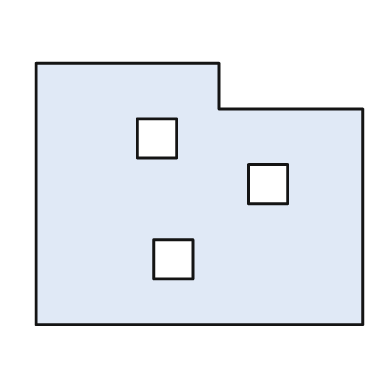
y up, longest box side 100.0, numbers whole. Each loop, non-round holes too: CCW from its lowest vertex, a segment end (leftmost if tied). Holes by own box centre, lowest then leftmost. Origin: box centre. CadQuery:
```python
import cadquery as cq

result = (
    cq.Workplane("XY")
    .moveTo(-50.0, -40.0)
    .lineTo(50.0, -40.0)
    .lineTo(50.0, 26.0)
    .lineTo(6.0, 26.0)
    .lineTo(6.0, 40.0)
    .lineTo(-50.0, 40.0)
    .close()
    .moveTo(-14.0, -26.0)
    .lineTo(-2.0, -26.0)
    .lineTo(-2.0, -14.0)
    .lineTo(-14.0, -14.0)
    .close()
    .moveTo(15.0, -3.0)
    .lineTo(27.0, -3.0)
    .lineTo(27.0, 9.0)
    .lineTo(15.0, 9.0)
    .close()
    .moveTo(-19.0, 11.0)
    .lineTo(-7.0, 11.0)
    .lineTo(-7.0, 23.0)
    .lineTo(-19.0, 23.0)
    .close()
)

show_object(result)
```